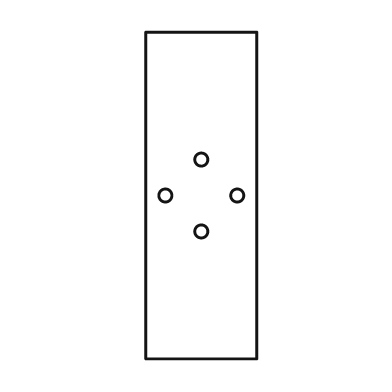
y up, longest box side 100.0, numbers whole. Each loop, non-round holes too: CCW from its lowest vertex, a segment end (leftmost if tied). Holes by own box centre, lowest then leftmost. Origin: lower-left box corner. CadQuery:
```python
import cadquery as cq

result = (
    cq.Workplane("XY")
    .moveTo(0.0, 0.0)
    .lineTo(34.0, 0.0)
    .lineTo(34.0, 100.0)
    .lineTo(0.0, 100.0)
    .close()
    .moveTo(17.0, 39.0)
    .circle(2.0)
    .moveTo(6.0, 50.0)
    .circle(2.0)
    .moveTo(28.0, 50.0)
    .circle(2.0)
    .moveTo(17.0, 61.0)
    .circle(2.0)
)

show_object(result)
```